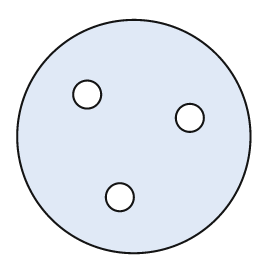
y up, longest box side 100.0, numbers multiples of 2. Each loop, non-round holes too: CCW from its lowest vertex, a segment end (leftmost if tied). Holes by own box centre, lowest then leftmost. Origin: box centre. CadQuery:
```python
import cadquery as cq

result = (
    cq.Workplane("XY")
    .moveTo(0.0, 0.0)
    .circle(50.0)
    .moveTo(-6.0, -26.0)
    .circle(6.0)
    .moveTo(24.0, 8.0)
    .circle(6.0)
    .moveTo(-20.0, 18.0)
    .circle(6.0)
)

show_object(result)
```